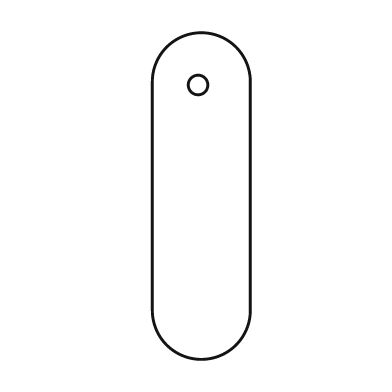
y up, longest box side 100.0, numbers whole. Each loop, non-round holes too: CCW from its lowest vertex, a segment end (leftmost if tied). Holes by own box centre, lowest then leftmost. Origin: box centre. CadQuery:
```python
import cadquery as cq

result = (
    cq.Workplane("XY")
    .moveTo(-15.0, -35.0)
    .threePointArc((0.0, -50.0), (15.0, -35.0))
    .lineTo(15.0, 35.0)
    .threePointArc((0.0, 50.0), (-15.0, 35.0))
    .close()
    .moveTo(-1.0, 34.0)
    .circle(3.0)
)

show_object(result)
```